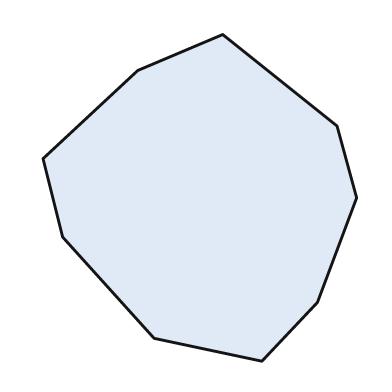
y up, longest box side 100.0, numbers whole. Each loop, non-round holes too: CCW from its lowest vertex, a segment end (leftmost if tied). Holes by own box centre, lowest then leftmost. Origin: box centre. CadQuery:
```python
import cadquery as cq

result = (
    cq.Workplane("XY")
    .moveTo(19.0, -50.0)
    .lineTo(36.0, -32.0)
    .lineTo(48.0, 0.0)
    .lineTo(42.0, 22.0)
    .lineTo(7.0, 50.0)
    .lineTo(-19.0, 39.0)
    .lineTo(-48.0, 12.0)
    .lineTo(-42.0, -12.0)
    .lineTo(-14.0, -43.0)
    .close()
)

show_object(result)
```